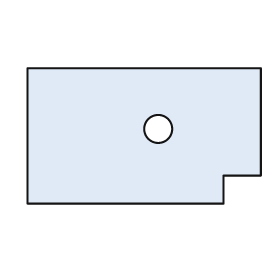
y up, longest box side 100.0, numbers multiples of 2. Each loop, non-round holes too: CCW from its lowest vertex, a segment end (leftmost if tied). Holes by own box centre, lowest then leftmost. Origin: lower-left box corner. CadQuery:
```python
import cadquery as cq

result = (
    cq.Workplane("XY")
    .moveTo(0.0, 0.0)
    .lineTo(84.0, 0.0)
    .lineTo(84.0, 12.0)
    .lineTo(100.0, 12.0)
    .lineTo(100.0, 58.0)
    .lineTo(0.0, 58.0)
    .close()
    .moveTo(56.0, 32.0)
    .circle(6.0)
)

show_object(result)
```